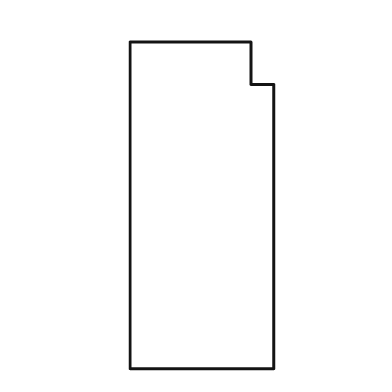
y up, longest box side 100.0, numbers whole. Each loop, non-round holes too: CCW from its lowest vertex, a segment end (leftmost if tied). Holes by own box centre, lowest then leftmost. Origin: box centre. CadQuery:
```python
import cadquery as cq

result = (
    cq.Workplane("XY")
    .moveTo(-22.0, -50.0)
    .lineTo(22.0, -50.0)
    .lineTo(22.0, 37.0)
    .lineTo(15.0, 37.0)
    .lineTo(15.0, 50.0)
    .lineTo(-22.0, 50.0)
    .close()
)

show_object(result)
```